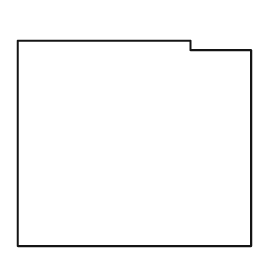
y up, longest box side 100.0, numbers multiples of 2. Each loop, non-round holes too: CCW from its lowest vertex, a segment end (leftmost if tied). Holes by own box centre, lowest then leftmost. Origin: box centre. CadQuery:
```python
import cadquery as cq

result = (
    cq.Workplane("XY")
    .moveTo(-50.0, -44.0)
    .lineTo(50.0, -44.0)
    .lineTo(50.0, 40.0)
    .lineTo(24.0, 40.0)
    .lineTo(24.0, 44.0)
    .lineTo(-50.0, 44.0)
    .close()
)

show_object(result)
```